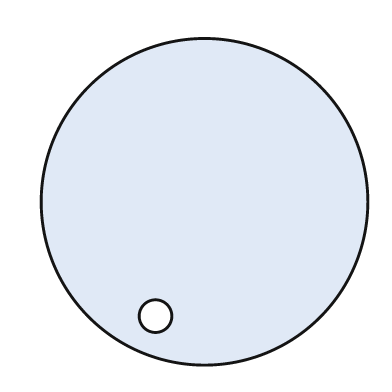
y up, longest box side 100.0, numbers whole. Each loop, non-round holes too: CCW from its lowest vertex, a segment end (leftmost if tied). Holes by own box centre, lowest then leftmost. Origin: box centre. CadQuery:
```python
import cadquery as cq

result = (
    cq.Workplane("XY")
    .moveTo(0.0, 0.0)
    .circle(50.0)
    .moveTo(-15.0, -35.0)
    .circle(5.0)
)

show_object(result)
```